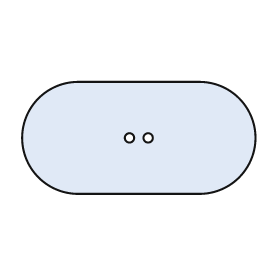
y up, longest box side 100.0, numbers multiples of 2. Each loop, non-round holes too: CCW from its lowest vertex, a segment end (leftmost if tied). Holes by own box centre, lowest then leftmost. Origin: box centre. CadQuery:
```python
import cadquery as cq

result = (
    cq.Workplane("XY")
    .moveTo(-26.0, -24.0)
    .lineTo(26.0, -24.0)
    .threePointArc((50.0, 0.0), (26.0, 24.0))
    .lineTo(-26.0, 24.0)
    .threePointArc((-50.0, 0.0), (-26.0, -24.0))
    .close()
    .moveTo(-4.0, 0.0)
    .circle(2.0)
    .moveTo(4.0, 0.0)
    .circle(2.0)
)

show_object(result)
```